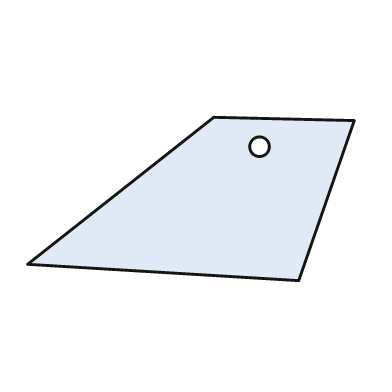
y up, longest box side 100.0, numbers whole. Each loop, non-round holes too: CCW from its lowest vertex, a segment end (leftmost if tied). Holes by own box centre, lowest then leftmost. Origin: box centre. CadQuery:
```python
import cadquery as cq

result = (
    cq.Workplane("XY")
    .moveTo(33.0, -25.0)
    .lineTo(50.0, 24.0)
    .lineTo(7.0, 25.0)
    .lineTo(-50.0, -20.0)
    .close()
    .moveTo(21.0, 16.0)
    .circle(3.0)
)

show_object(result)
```